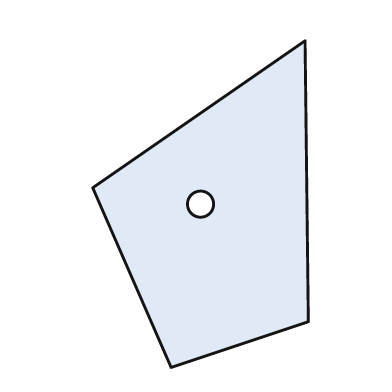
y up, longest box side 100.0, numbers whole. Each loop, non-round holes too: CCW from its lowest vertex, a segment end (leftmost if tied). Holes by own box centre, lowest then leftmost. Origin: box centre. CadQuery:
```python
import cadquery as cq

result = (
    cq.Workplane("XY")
    .moveTo(-9.0, -50.0)
    .lineTo(33.0, -36.0)
    .lineTo(32.0, 50.0)
    .lineTo(-33.0, 5.0)
    .close()
    .moveTo(0.0, 0.0)
    .circle(4.0)
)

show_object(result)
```